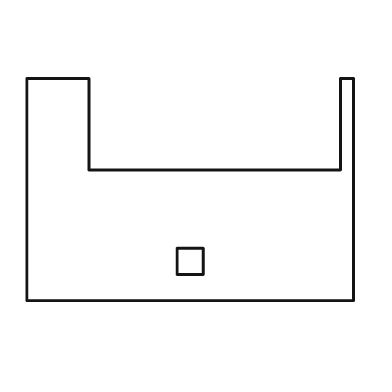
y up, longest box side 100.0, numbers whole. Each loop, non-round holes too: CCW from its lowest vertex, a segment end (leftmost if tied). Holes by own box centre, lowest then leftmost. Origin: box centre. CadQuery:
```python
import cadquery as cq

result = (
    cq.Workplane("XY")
    .moveTo(-50.0, -34.0)
    .lineTo(50.0, -34.0)
    .lineTo(50.0, 34.0)
    .lineTo(46.0, 34.0)
    .lineTo(46.0, 6.0)
    .lineTo(-31.0, 6.0)
    .lineTo(-31.0, 34.0)
    .lineTo(-50.0, 34.0)
    .close()
    .moveTo(-4.0, -26.0)
    .lineTo(4.0, -26.0)
    .lineTo(4.0, -18.0)
    .lineTo(-4.0, -18.0)
    .close()
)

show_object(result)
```